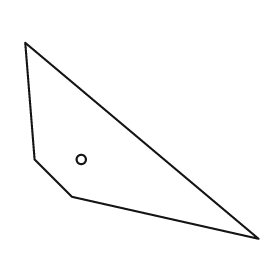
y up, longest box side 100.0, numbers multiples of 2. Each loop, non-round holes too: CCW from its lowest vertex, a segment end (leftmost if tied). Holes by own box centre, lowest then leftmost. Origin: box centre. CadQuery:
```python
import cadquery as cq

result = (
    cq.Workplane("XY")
    .moveTo(50.0, -42.0)
    .lineTo(-50.0, 42.0)
    .lineTo(-46.0, -8.0)
    .lineTo(-30.0, -24.0)
    .close()
    .moveTo(-26.0, -8.0)
    .circle(2.0)
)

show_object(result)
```